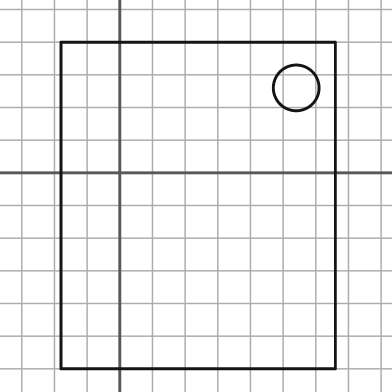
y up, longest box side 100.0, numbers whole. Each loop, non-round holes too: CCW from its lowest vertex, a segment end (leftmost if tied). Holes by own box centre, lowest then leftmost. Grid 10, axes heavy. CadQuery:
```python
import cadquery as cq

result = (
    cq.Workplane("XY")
    .moveTo(-18.0, -60.0)
    .lineTo(66.0, -60.0)
    .lineTo(66.0, 40.0)
    .lineTo(-18.0, 40.0)
    .close()
    .moveTo(54.0, 26.0)
    .circle(7.0)
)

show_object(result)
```